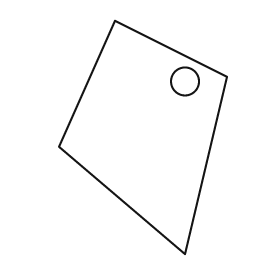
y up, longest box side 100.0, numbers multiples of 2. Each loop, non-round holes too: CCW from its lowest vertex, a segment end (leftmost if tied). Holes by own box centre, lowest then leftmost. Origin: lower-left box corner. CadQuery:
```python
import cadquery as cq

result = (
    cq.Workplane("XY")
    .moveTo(54.0, 0.0)
    .lineTo(72.0, 76.0)
    .lineTo(24.0, 100.0)
    .lineTo(0.0, 46.0)
    .close()
    .moveTo(54.0, 74.0)
    .circle(6.0)
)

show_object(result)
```